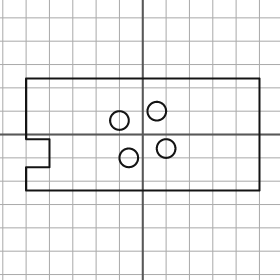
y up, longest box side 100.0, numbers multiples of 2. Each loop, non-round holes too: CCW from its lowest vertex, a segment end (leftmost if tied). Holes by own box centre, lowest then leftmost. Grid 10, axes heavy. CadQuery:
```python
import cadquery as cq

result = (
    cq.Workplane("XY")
    .moveTo(-50.0, -24.0)
    .lineTo(50.0, -24.0)
    .lineTo(50.0, 24.0)
    .lineTo(-50.0, 24.0)
    .lineTo(-50.0, -2.0)
    .lineTo(-40.0, -2.0)
    .lineTo(-40.0, -14.0)
    .lineTo(-50.0, -14.0)
    .close()
    .moveTo(-6.0, -10.0)
    .circle(4.0)
    .moveTo(10.0, -6.0)
    .circle(4.0)
    .moveTo(-10.0, 6.0)
    .circle(4.0)
    .moveTo(6.0, 10.0)
    .circle(4.0)
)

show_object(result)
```